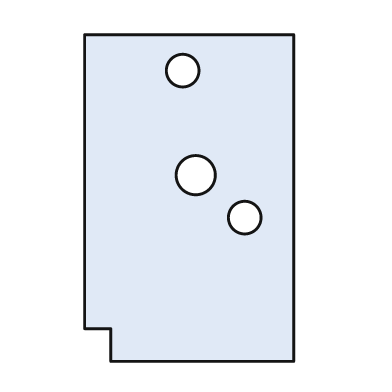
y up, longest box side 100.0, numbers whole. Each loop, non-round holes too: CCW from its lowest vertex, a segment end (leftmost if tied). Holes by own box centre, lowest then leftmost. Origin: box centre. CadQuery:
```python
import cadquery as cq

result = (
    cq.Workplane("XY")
    .moveTo(-24.0, -50.0)
    .lineTo(32.0, -50.0)
    .lineTo(32.0, 50.0)
    .lineTo(-32.0, 50.0)
    .lineTo(-32.0, -40.0)
    .lineTo(-24.0, -40.0)
    .close()
    .moveTo(17.0, -6.0)
    .circle(5.0)
    .moveTo(2.0, 7.0)
    .circle(6.0)
    .moveTo(-2.0, 39.0)
    .circle(5.0)
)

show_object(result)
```